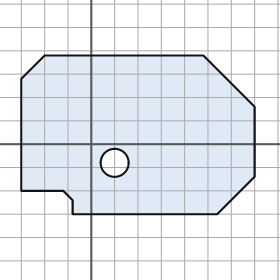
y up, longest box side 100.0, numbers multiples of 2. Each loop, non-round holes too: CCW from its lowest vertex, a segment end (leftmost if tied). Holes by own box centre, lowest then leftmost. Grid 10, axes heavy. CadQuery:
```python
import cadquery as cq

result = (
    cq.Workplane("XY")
    .moveTo(-8.0, -30.0)
    .lineTo(54.0, -30.0)
    .lineTo(70.0, -14.0)
    .lineTo(70.0, 16.0)
    .lineTo(48.0, 38.0)
    .lineTo(-20.0, 38.0)
    .lineTo(-30.0, 28.0)
    .lineTo(-30.0, -20.0)
    .lineTo(-12.0, -20.0)
    .lineTo(-8.0, -24.0)
    .close()
    .moveTo(10.0, -8.0)
    .circle(6.0)
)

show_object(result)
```